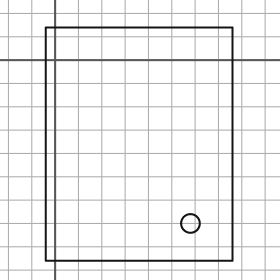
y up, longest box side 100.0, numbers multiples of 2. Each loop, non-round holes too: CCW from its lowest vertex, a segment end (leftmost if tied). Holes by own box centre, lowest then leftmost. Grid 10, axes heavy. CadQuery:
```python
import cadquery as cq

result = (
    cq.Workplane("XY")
    .moveTo(-4.0, -86.0)
    .lineTo(76.0, -86.0)
    .lineTo(76.0, 14.0)
    .lineTo(-4.0, 14.0)
    .close()
    .moveTo(58.0, -70.0)
    .circle(4.0)
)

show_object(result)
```